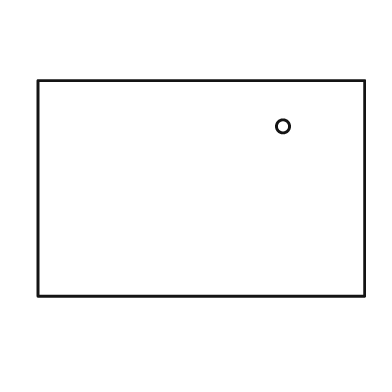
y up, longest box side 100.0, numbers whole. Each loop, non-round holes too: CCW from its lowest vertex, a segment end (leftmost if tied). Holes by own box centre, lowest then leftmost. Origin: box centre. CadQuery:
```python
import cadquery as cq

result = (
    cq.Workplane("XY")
    .moveTo(-50.0, -33.0)
    .lineTo(50.0, -33.0)
    .lineTo(50.0, 33.0)
    .lineTo(-50.0, 33.0)
    .close()
    .moveTo(25.0, 19.0)
    .circle(2.0)
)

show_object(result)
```